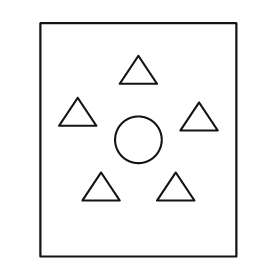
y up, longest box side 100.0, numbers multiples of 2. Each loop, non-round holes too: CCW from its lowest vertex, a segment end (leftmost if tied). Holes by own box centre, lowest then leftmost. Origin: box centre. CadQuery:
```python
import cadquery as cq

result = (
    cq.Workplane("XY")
    .moveTo(-42.0, -50.0)
    .lineTo(42.0, -50.0)
    .lineTo(42.0, 50.0)
    .lineTo(-42.0, 50.0)
    .close()
    .moveTo(-24.0, -26.0)
    .lineTo(-8.0, -26.0)
    .lineTo(-16.0, -14.0)
    .close()
    .moveTo(8.0, -26.0)
    .lineTo(24.0, -26.0)
    .lineTo(16.0, -14.0)
    .close()
    .moveTo(0.0, 0.0)
    .circle(10.0)
    .moveTo(18.0, 4.0)
    .lineTo(34.0, 4.0)
    .lineTo(26.0, 16.0)
    .close()
    .moveTo(-34.0, 6.0)
    .lineTo(-18.0, 6.0)
    .lineTo(-26.0, 18.0)
    .close()
    .moveTo(-8.0, 24.0)
    .lineTo(8.0, 24.0)
    .lineTo(0.0, 36.0)
    .close()
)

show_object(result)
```